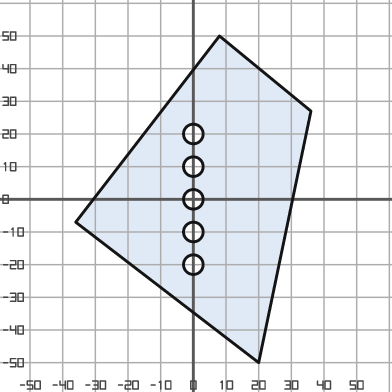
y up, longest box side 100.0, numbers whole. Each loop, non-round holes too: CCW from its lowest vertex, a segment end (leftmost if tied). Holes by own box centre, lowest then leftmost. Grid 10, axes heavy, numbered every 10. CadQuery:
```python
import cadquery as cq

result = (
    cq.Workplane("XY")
    .moveTo(20.0, -50.0)
    .lineTo(36.0, 27.0)
    .lineTo(8.0, 50.0)
    .lineTo(-36.0, -7.0)
    .close()
    .moveTo(0.0, -20.0)
    .circle(3.0)
    .moveTo(0.0, -10.0)
    .circle(3.0)
    .moveTo(0.0, 0.0)
    .circle(3.0)
    .moveTo(0.0, 10.0)
    .circle(3.0)
    .moveTo(0.0, 20.0)
    .circle(3.0)
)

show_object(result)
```